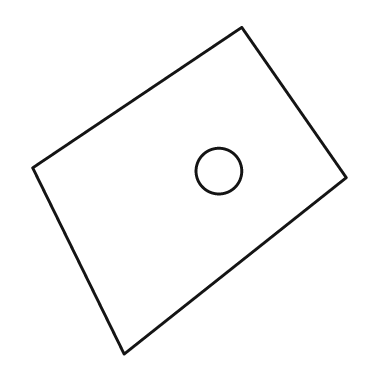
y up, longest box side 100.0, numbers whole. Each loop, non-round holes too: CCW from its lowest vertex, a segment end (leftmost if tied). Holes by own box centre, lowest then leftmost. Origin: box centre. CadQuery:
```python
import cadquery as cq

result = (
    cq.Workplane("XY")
    .moveTo(-20.0, -50.0)
    .lineTo(48.0, 4.0)
    .lineTo(16.0, 50.0)
    .lineTo(-48.0, 7.0)
    .close()
    .moveTo(9.0, 6.0)
    .circle(7.0)
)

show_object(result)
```